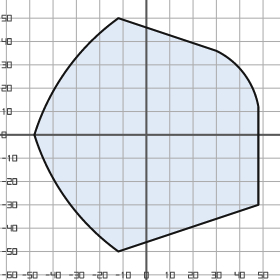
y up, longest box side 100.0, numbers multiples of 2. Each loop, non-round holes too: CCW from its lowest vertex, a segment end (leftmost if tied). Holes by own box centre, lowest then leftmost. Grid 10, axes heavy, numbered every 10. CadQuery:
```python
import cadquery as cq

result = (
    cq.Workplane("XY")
    .moveTo(-12.0, -50.0)
    .lineTo(48.0, -30.0)
    .lineTo(48.0, 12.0)
    .threePointArc((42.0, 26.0), (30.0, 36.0))
    .lineTo(-12.0, 50.0)
    .threePointArc((-34.0, 28.0), (-48.0, 0.0))
    .threePointArc((-34.0, -28.0), (-12.0, -50.0))
    .close()
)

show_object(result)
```